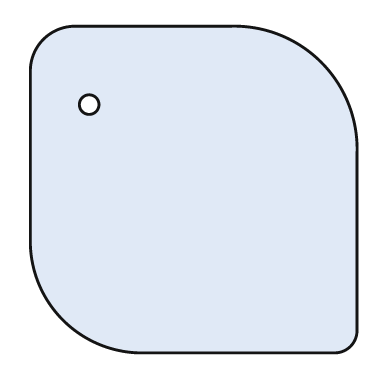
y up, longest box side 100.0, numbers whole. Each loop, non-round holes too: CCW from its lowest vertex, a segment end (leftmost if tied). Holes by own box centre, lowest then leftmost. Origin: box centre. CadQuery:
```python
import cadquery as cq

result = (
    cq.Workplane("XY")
    .moveTo(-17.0, -50.0)
    .lineTo(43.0, -50.0)
    .threePointArc((48.0, -48.0), (50.0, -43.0))
    .lineTo(50.0, 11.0)
    .threePointArc((39.0, 39.0), (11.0, 50.0))
    .lineTo(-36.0, 50.0)
    .threePointArc((-46.0, 46.0), (-50.0, 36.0))
    .lineTo(-50.0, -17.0)
    .threePointArc((-40.0, -40.0), (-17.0, -50.0))
    .close()
    .moveTo(-32.0, 26.0)
    .circle(3.0)
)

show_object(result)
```